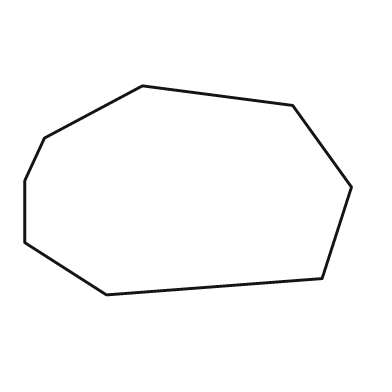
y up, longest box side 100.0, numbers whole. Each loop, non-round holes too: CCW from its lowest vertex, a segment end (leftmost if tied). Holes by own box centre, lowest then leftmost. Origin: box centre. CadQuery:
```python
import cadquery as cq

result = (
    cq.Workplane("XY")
    .moveTo(-25.0, -32.0)
    .lineTo(41.0, -27.0)
    .lineTo(50.0, 1.0)
    .lineTo(32.0, 26.0)
    .lineTo(-14.0, 32.0)
    .lineTo(-44.0, 16.0)
    .lineTo(-50.0, 3.0)
    .lineTo(-50.0, -16.0)
    .close()
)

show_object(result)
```